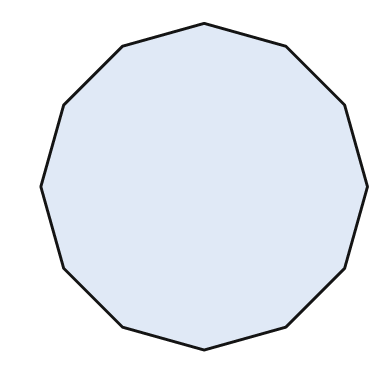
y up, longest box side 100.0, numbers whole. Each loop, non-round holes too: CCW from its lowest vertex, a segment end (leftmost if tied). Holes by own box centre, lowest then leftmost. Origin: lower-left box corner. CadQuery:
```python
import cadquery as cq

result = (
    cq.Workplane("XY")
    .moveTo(50.0, 0.0)
    .lineTo(75.0, 7.0)
    .lineTo(93.0, 25.0)
    .lineTo(100.0, 50.0)
    .lineTo(93.0, 75.0)
    .lineTo(75.0, 93.0)
    .lineTo(50.0, 100.0)
    .lineTo(25.0, 93.0)
    .lineTo(7.0, 75.0)
    .lineTo(0.0, 50.0)
    .lineTo(7.0, 25.0)
    .lineTo(25.0, 7.0)
    .close()
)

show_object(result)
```